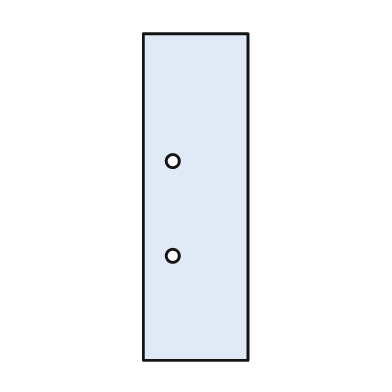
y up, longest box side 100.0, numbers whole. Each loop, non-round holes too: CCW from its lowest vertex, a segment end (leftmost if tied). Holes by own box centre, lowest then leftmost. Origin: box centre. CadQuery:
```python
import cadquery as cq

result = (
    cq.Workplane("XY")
    .moveTo(-16.0, -50.0)
    .lineTo(16.0, -50.0)
    .lineTo(16.0, 50.0)
    .lineTo(-16.0, 50.0)
    .close()
    .moveTo(-7.0, -18.0)
    .circle(2.0)
    .moveTo(-7.0, 11.0)
    .circle(2.0)
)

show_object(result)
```